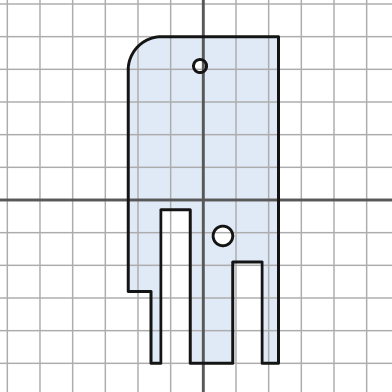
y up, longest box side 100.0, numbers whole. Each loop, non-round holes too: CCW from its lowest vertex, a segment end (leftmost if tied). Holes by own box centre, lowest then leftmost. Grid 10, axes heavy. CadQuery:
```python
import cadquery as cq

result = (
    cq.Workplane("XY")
    .moveTo(-16.0, -50.0)
    .lineTo(-13.0, -50.0)
    .lineTo(-13.0, -3.0)
    .lineTo(-4.0, -3.0)
    .lineTo(-4.0, -50.0)
    .lineTo(9.0, -50.0)
    .lineTo(9.0, -19.0)
    .lineTo(18.0, -19.0)
    .lineTo(18.0, -50.0)
    .lineTo(23.0, -50.0)
    .lineTo(23.0, 50.0)
    .lineTo(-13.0, 50.0)
    .threePointArc((-20.0, 47.0), (-23.0, 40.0))
    .lineTo(-23.0, -28.0)
    .lineTo(-16.0, -28.0)
    .close()
    .moveTo(6.0, -11.0)
    .circle(3.0)
    .moveTo(-1.0, 41.0)
    .circle(2.0)
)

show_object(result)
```